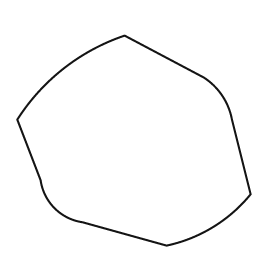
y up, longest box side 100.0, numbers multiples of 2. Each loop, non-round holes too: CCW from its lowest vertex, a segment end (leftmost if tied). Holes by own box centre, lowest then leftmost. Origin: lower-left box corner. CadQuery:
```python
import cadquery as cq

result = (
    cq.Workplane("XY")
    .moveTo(64.0, 0.0)
    .threePointArc((84.0, 8.0), (100.0, 22.0))
    .lineTo(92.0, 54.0)
    .threePointArc((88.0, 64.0), (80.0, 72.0))
    .lineTo(46.0, 90.0)
    .threePointArc((20.0, 76.0), (0.0, 54.0))
    .lineTo(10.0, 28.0)
    .threePointArc((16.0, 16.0), (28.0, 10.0))
    .close()
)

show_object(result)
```